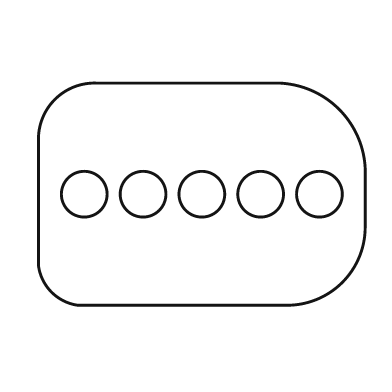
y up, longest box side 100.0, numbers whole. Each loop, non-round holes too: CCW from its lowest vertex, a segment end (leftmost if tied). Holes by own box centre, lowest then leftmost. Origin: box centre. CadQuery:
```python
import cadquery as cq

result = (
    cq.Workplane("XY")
    .moveTo(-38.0, -34.0)
    .lineTo(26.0, -34.0)
    .threePointArc((43.0, -27.0), (50.0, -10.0))
    .lineTo(50.0, 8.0)
    .threePointArc((42.0, 26.0), (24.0, 34.0))
    .lineTo(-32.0, 34.0)
    .threePointArc((-45.0, 29.0), (-50.0, 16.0))
    .lineTo(-50.0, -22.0)
    .threePointArc((-46.0, -30.0), (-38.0, -34.0))
    .close()
    .moveTo(-36.0, 0.0)
    .circle(7.0)
    .moveTo(-18.0, 0.0)
    .circle(7.0)
    .moveTo(0.0, 0.0)
    .circle(7.0)
    .moveTo(18.0, 0.0)
    .circle(7.0)
    .moveTo(36.0, 0.0)
    .circle(7.0)
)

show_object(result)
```